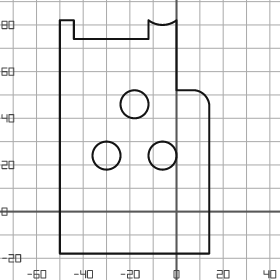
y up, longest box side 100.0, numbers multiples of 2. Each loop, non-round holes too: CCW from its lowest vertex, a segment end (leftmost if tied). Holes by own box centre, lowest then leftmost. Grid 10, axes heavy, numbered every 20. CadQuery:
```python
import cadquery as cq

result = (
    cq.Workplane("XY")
    .moveTo(-50.0, -18.0)
    .lineTo(14.0, -18.0)
    .lineTo(14.0, 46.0)
    .threePointArc((12.0, 50.0), (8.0, 52.0))
    .lineTo(0.0, 52.0)
    .lineTo(0.0, 82.0)
    .threePointArc((-6.0, 80.0), (-12.0, 82.0))
    .lineTo(-12.0, 74.0)
    .lineTo(-44.0, 74.0)
    .lineTo(-44.0, 82.0)
    .lineTo(-50.0, 82.0)
    .close()
    .moveTo(-30.0, 24.0)
    .circle(6.0)
    .moveTo(-6.0, 24.0)
    .circle(6.0)
    .moveTo(-18.0, 46.0)
    .circle(6.0)
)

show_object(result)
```